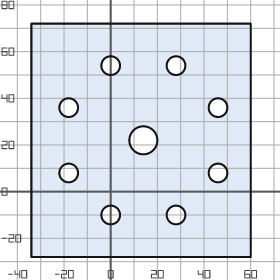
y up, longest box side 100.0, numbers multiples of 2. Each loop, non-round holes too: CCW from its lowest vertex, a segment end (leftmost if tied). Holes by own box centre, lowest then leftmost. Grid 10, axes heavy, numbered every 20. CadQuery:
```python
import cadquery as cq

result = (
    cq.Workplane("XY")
    .moveTo(-34.0, -28.0)
    .lineTo(60.0, -28.0)
    .lineTo(60.0, 72.0)
    .lineTo(-34.0, 72.0)
    .close()
    .moveTo(0.0, -10.0)
    .circle(4.0)
    .moveTo(28.0, -10.0)
    .circle(4.0)
    .moveTo(-18.0, 8.0)
    .circle(4.0)
    .moveTo(46.0, 8.0)
    .circle(4.0)
    .moveTo(14.0, 22.0)
    .circle(6.0)
    .moveTo(-18.0, 36.0)
    .circle(4.0)
    .moveTo(46.0, 36.0)
    .circle(4.0)
    .moveTo(0.0, 54.0)
    .circle(4.0)
    .moveTo(28.0, 54.0)
    .circle(4.0)
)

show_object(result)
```